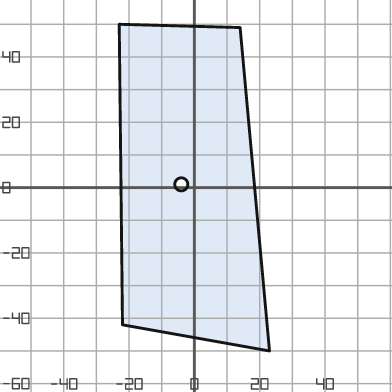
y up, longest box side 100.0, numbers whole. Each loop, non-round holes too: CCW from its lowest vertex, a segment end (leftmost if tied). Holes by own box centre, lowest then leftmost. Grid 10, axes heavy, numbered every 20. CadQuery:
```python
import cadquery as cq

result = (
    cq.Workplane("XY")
    .moveTo(23.0, -50.0)
    .lineTo(14.0, 49.0)
    .lineTo(-23.0, 50.0)
    .lineTo(-22.0, -42.0)
    .close()
    .moveTo(-4.0, 1.0)
    .circle(2.0)
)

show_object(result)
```